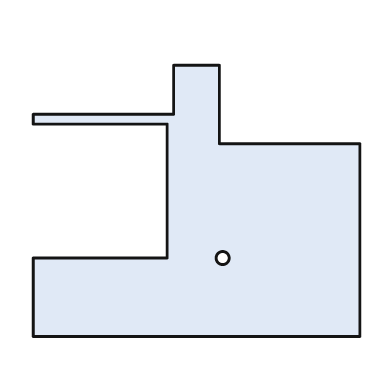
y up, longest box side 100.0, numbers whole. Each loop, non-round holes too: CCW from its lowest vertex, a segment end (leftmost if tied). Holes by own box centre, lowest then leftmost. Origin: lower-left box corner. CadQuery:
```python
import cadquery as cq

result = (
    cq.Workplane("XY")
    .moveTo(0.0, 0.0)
    .lineTo(100.0, 0.0)
    .lineTo(100.0, 59.0)
    .lineTo(57.0, 59.0)
    .lineTo(57.0, 83.0)
    .lineTo(43.0, 83.0)
    .lineTo(43.0, 68.0)
    .lineTo(0.0, 68.0)
    .lineTo(0.0, 65.0)
    .lineTo(41.0, 65.0)
    .lineTo(41.0, 24.0)
    .lineTo(0.0, 24.0)
    .close()
    .moveTo(58.0, 24.0)
    .circle(2.0)
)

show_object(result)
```